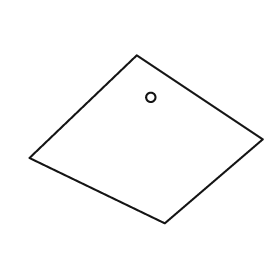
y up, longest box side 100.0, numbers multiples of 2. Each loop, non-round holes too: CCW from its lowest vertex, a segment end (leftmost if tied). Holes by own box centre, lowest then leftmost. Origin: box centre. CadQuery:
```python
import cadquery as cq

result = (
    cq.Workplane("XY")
    .moveTo(8.0, -36.0)
    .lineTo(50.0, 0.0)
    .lineTo(-4.0, 36.0)
    .lineTo(-50.0, -8.0)
    .close()
    .moveTo(2.0, 18.0)
    .circle(2.0)
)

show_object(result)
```